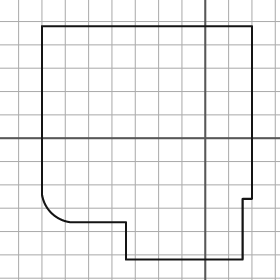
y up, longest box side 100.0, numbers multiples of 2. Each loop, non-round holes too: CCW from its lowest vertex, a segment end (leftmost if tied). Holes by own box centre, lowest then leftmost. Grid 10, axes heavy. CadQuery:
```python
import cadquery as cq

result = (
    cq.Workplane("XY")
    .moveTo(-34.0, -52.0)
    .lineTo(16.0, -52.0)
    .lineTo(16.0, -26.0)
    .lineTo(20.0, -26.0)
    .lineTo(20.0, 48.0)
    .lineTo(-70.0, 48.0)
    .lineTo(-70.0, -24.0)
    .threePointArc((-66.0, -32.0), (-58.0, -36.0))
    .lineTo(-34.0, -36.0)
    .close()
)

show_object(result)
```